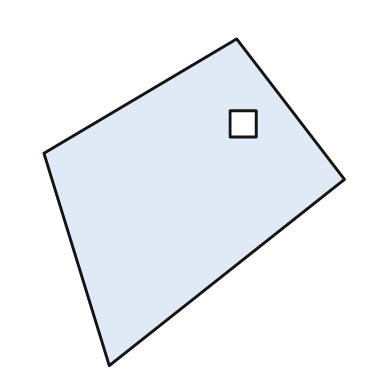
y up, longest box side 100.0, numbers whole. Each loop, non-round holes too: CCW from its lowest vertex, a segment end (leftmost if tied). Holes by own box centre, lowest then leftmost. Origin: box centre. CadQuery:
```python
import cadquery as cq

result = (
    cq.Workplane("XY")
    .moveTo(-26.0, -50.0)
    .lineTo(46.0, 7.0)
    .lineTo(13.0, 50.0)
    .lineTo(-46.0, 15.0)
    .close()
    .moveTo(11.0, 20.0)
    .lineTo(19.0, 20.0)
    .lineTo(19.0, 28.0)
    .lineTo(11.0, 28.0)
    .close()
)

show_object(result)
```